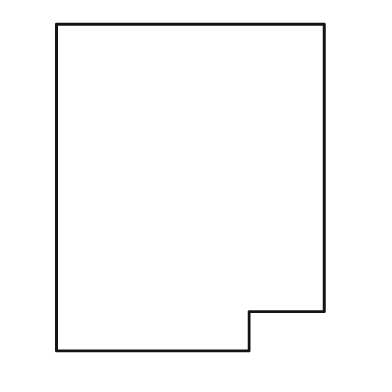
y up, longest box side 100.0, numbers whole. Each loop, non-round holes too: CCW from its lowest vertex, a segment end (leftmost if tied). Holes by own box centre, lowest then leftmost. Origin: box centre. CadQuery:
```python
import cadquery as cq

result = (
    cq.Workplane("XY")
    .moveTo(-41.0, -50.0)
    .lineTo(18.0, -50.0)
    .lineTo(18.0, -38.0)
    .lineTo(41.0, -38.0)
    .lineTo(41.0, 50.0)
    .lineTo(-41.0, 50.0)
    .close()
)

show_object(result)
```